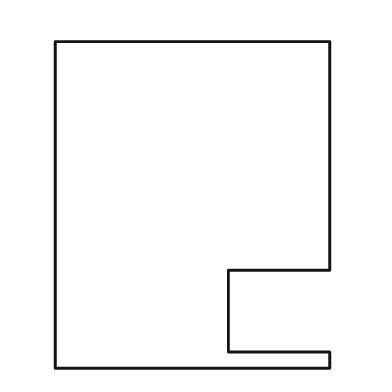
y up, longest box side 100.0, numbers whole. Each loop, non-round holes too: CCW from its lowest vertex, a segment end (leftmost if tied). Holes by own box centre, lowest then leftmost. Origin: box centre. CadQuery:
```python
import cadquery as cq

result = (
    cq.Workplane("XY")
    .moveTo(-42.0, -50.0)
    .lineTo(42.0, -50.0)
    .lineTo(42.0, -45.0)
    .lineTo(11.0, -45.0)
    .lineTo(11.0, -20.0)
    .lineTo(42.0, -20.0)
    .lineTo(42.0, 50.0)
    .lineTo(-42.0, 50.0)
    .close()
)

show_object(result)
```